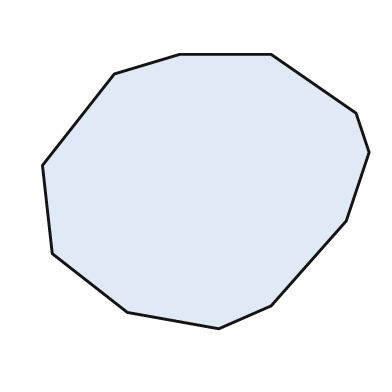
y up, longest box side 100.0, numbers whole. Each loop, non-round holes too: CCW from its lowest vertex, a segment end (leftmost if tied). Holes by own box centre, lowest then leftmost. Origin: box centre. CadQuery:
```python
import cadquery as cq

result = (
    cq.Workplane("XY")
    .moveTo(4.0, -42.0)
    .lineTo(20.0, -35.0)
    .lineTo(43.0, -9.0)
    .lineTo(50.0, 12.0)
    .lineTo(46.0, 24.0)
    .lineTo(20.0, 42.0)
    .lineTo(-8.0, 42.0)
    .lineTo(-28.0, 36.0)
    .lineTo(-50.0, 8.0)
    .lineTo(-47.0, -19.0)
    .lineTo(-24.0, -37.0)
    .close()
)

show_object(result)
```